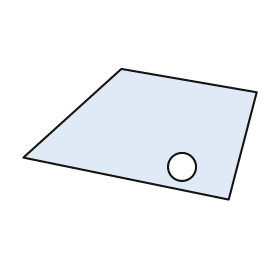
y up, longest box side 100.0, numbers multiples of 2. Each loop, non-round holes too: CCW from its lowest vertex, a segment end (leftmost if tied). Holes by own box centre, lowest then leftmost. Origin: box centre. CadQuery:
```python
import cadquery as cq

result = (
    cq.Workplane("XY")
    .moveTo(38.0, -28.0)
    .lineTo(50.0, 18.0)
    .lineTo(-8.0, 28.0)
    .lineTo(-50.0, -10.0)
    .close()
    .moveTo(18.0, -14.0)
    .circle(6.0)
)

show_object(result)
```